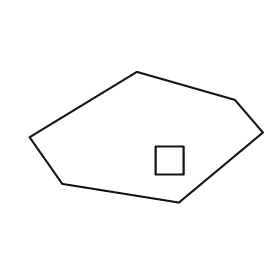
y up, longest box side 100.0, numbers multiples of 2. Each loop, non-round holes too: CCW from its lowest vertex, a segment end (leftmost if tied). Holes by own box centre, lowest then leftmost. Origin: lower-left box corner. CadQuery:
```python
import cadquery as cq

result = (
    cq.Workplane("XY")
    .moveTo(64.0, 0.0)
    .lineTo(100.0, 30.0)
    .lineTo(88.0, 44.0)
    .lineTo(46.0, 56.0)
    .lineTo(0.0, 28.0)
    .lineTo(14.0, 8.0)
    .close()
    .moveTo(54.0, 12.0)
    .lineTo(66.0, 12.0)
    .lineTo(66.0, 24.0)
    .lineTo(54.0, 24.0)
    .close()
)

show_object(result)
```